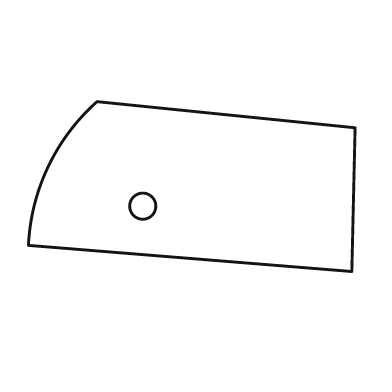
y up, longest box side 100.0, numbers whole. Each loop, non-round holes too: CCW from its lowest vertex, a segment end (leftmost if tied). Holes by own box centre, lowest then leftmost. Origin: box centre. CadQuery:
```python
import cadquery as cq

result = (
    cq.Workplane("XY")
    .moveTo(49.0, -26.0)
    .lineTo(50.0, 18.0)
    .lineTo(-29.0, 26.0)
    .threePointArc((-44.0, 6.0), (-50.0, -18.0))
    .close()
    .moveTo(-15.0, -6.0)
    .circle(4.0)
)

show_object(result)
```